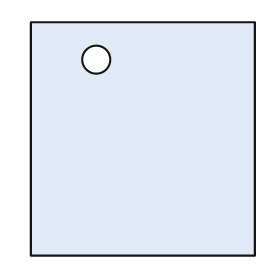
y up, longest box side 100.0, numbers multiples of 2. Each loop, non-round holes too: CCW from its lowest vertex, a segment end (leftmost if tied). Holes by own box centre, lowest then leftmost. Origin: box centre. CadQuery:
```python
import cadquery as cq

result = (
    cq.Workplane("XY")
    .moveTo(-48.0, -50.0)
    .lineTo(48.0, -50.0)
    .lineTo(48.0, 50.0)
    .lineTo(-48.0, 50.0)
    .close()
    .moveTo(-20.0, 34.0)
    .circle(6.0)
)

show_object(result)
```